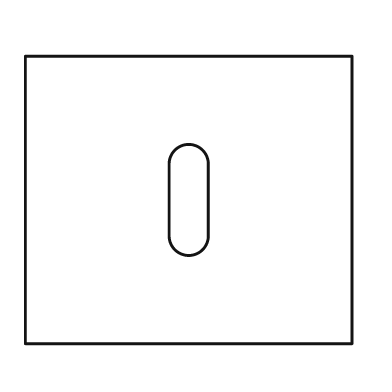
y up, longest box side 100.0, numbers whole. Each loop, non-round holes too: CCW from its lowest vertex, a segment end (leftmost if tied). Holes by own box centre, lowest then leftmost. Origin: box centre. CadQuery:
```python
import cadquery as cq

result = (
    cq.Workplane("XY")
    .moveTo(-50.0, -44.0)
    .lineTo(50.0, -44.0)
    .lineTo(50.0, 44.0)
    .lineTo(-50.0, 44.0)
    .close()
    .moveTo(-6.0, -11.0)
    .threePointArc((0.0, -17.0), (6.0, -11.0))
    .lineTo(6.0, 11.0)
    .threePointArc((0.0, 17.0), (-6.0, 11.0))
    .close()
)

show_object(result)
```